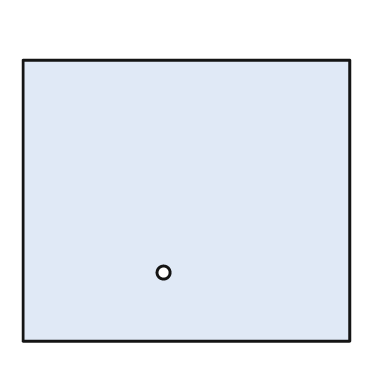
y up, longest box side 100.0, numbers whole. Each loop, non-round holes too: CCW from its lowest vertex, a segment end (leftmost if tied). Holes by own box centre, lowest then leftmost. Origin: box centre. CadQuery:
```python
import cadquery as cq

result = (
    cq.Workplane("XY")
    .moveTo(-50.0, -43.0)
    .lineTo(50.0, -43.0)
    .lineTo(50.0, 43.0)
    .lineTo(-50.0, 43.0)
    .close()
    .moveTo(-7.0, -22.0)
    .circle(2.0)
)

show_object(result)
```